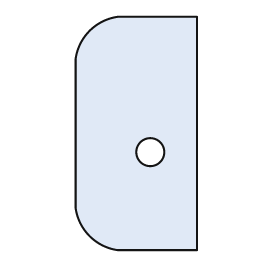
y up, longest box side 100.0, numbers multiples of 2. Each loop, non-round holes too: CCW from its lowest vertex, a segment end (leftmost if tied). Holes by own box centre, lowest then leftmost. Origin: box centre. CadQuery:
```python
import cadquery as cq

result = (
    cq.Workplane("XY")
    .moveTo(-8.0, -50.0)
    .lineTo(26.0, -50.0)
    .lineTo(26.0, 50.0)
    .lineTo(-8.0, 50.0)
    .threePointArc((-20.0, 44.0), (-26.0, 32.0))
    .lineTo(-26.0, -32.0)
    .threePointArc((-20.0, -44.0), (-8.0, -50.0))
    .close()
    .moveTo(6.0, -8.0)
    .circle(6.0)
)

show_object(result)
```